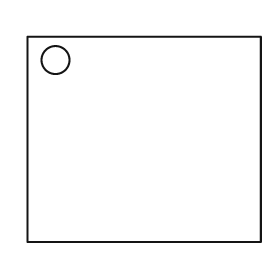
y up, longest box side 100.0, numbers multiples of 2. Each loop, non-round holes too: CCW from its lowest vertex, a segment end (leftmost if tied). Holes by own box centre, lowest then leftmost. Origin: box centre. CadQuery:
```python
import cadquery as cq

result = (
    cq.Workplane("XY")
    .moveTo(-50.0, -44.0)
    .lineTo(50.0, -44.0)
    .lineTo(50.0, 44.0)
    .lineTo(-50.0, 44.0)
    .close()
    .moveTo(-38.0, 34.0)
    .circle(6.0)
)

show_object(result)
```